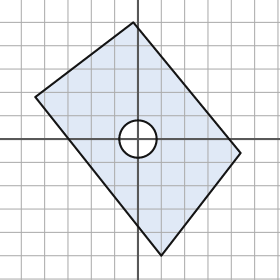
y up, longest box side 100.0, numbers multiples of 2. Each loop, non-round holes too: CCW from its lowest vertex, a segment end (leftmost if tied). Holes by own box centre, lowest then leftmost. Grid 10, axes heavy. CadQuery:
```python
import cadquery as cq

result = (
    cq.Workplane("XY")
    .moveTo(10.0, -50.0)
    .lineTo(44.0, -6.0)
    .lineTo(-2.0, 50.0)
    .lineTo(-44.0, 18.0)
    .close()
    .moveTo(0.0, 0.0)
    .circle(8.0)
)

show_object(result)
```